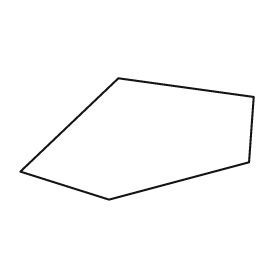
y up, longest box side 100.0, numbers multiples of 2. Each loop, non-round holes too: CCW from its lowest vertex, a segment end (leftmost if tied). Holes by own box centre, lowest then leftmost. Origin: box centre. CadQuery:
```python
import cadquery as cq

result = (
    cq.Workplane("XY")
    .moveTo(-12.0, -26.0)
    .lineTo(48.0, -10.0)
    .lineTo(50.0, 18.0)
    .lineTo(-8.0, 26.0)
    .lineTo(-50.0, -14.0)
    .close()
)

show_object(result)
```